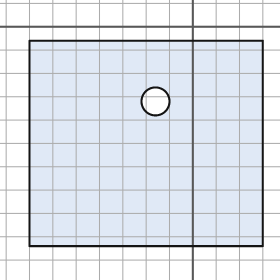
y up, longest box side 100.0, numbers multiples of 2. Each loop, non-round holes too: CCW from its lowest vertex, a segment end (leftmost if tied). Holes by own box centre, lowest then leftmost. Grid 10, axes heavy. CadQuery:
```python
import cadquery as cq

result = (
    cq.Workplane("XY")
    .moveTo(-70.0, -94.0)
    .lineTo(30.0, -94.0)
    .lineTo(30.0, -6.0)
    .lineTo(-70.0, -6.0)
    .close()
    .moveTo(-16.0, -32.0)
    .circle(6.0)
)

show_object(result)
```